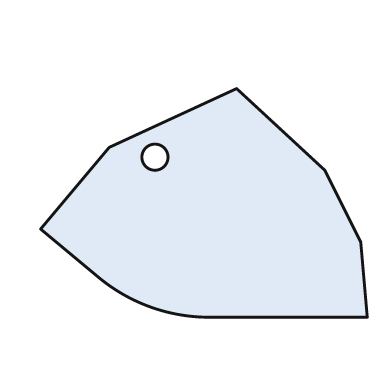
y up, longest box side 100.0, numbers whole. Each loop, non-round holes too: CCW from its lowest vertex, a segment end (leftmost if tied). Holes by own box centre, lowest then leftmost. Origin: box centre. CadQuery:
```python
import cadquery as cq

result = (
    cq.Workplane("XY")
    .moveTo(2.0, -35.0)
    .lineTo(50.0, -35.0)
    .lineTo(48.0, -12.0)
    .lineTo(37.0, 10.0)
    .lineTo(10.0, 35.0)
    .lineTo(-29.0, 17.0)
    .lineTo(-50.0, -8.0)
    .lineTo(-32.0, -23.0)
    .threePointArc((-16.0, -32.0), (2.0, -35.0))
    .close()
    .moveTo(-15.0, 14.0)
    .circle(4.0)
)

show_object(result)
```